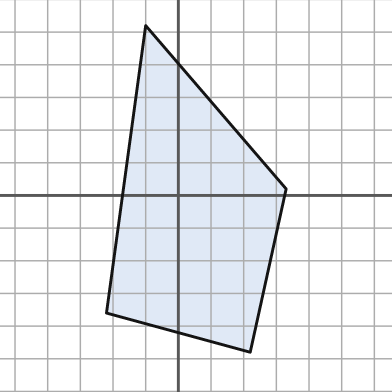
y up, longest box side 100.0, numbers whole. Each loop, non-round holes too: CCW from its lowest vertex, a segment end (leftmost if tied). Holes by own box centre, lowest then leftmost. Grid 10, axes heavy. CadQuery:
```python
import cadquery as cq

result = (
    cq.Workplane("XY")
    .moveTo(22.0, -48.0)
    .lineTo(33.0, 2.0)
    .lineTo(-10.0, 52.0)
    .lineTo(-22.0, -36.0)
    .close()
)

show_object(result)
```